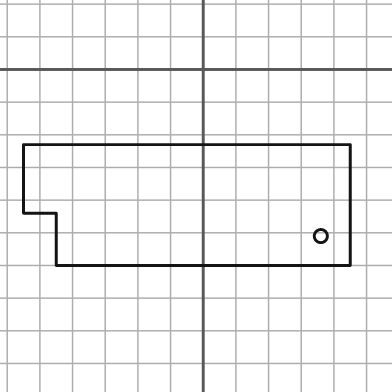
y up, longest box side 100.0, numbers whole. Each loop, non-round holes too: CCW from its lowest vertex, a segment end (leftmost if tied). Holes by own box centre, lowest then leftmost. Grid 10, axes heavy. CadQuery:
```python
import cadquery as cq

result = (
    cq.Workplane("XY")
    .moveTo(-45.0, -60.0)
    .lineTo(45.0, -60.0)
    .lineTo(45.0, -23.0)
    .lineTo(-55.0, -23.0)
    .lineTo(-55.0, -44.0)
    .lineTo(-45.0, -44.0)
    .close()
    .moveTo(36.0, -51.0)
    .circle(2.0)
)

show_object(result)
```